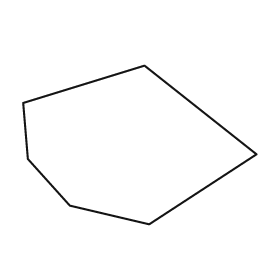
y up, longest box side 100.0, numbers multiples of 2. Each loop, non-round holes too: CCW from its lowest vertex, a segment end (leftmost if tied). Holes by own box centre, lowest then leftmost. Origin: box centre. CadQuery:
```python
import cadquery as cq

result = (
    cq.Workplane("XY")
    .moveTo(4.0, -34.0)
    .lineTo(50.0, -4.0)
    .lineTo(2.0, 34.0)
    .lineTo(-50.0, 18.0)
    .lineTo(-48.0, -6.0)
    .lineTo(-30.0, -26.0)
    .close()
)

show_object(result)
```